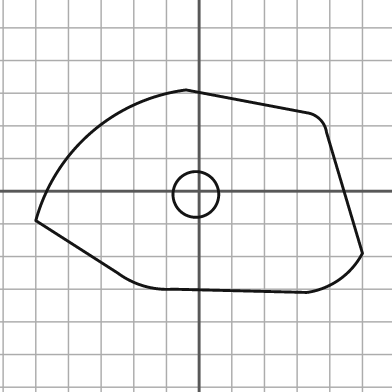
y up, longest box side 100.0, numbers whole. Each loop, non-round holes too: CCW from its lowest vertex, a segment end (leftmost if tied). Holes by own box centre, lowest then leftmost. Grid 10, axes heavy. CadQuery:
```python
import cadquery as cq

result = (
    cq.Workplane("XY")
    .moveTo(33.0, -31.0)
    .threePointArc((43.0, -27.0), (50.0, -19.0))
    .lineTo(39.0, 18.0)
    .threePointArc((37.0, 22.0), (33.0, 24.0))
    .lineTo(-4.0, 31.0)
    .threePointArc((-33.0, 18.0), (-50.0, -9.0))
    .lineTo(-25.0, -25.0)
    .threePointArc((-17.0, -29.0), (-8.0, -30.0))
    .close()
    .moveTo(-1.0, -1.0)
    .circle(7.0)
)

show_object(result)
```